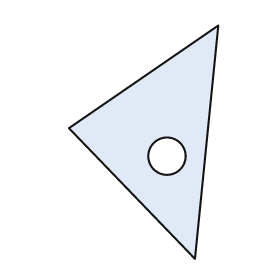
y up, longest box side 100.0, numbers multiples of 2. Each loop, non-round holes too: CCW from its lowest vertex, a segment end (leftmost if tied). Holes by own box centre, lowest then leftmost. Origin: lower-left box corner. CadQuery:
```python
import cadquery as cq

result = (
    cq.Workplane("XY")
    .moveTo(54.0, 0.0)
    .lineTo(64.0, 100.0)
    .lineTo(0.0, 56.0)
    .close()
    .moveTo(42.0, 44.0)
    .circle(8.0)
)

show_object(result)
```